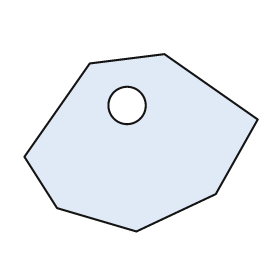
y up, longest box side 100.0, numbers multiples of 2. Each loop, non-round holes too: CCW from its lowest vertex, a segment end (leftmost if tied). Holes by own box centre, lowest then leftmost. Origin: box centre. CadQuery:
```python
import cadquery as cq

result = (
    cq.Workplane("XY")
    .moveTo(-2.0, -38.0)
    .lineTo(32.0, -22.0)
    .lineTo(50.0, 10.0)
    .lineTo(10.0, 38.0)
    .lineTo(-22.0, 34.0)
    .lineTo(-50.0, -6.0)
    .lineTo(-36.0, -28.0)
    .close()
    .moveTo(-6.0, 16.0)
    .circle(8.0)
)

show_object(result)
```